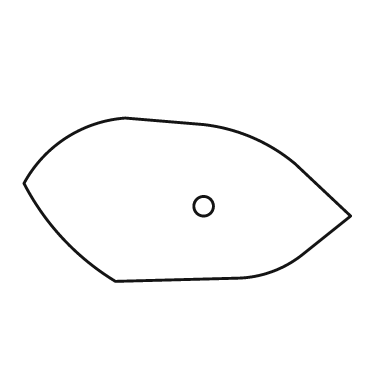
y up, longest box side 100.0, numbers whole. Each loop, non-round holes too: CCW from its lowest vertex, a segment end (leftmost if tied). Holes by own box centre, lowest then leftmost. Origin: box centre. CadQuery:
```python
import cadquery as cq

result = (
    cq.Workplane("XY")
    .moveTo(-22.0, -25.0)
    .lineTo(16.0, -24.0)
    .threePointArc((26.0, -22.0), (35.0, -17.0))
    .lineTo(50.0, -5.0)
    .lineTo(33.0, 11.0)
    .threePointArc((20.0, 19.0), (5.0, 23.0))
    .lineTo(-19.0, 25.0)
    .threePointArc((-37.0, 19.0), (-50.0, 5.0))
    .threePointArc((-38.0, -12.0), (-22.0, -25.0))
    .close()
    .moveTo(5.0, -2.0)
    .circle(3.0)
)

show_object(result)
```